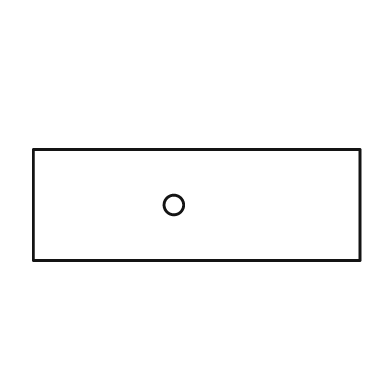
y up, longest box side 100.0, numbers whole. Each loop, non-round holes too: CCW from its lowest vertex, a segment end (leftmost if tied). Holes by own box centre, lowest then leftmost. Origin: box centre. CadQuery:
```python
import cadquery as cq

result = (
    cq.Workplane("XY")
    .moveTo(-50.0, -17.0)
    .lineTo(50.0, -17.0)
    .lineTo(50.0, 17.0)
    .lineTo(-50.0, 17.0)
    .close()
    .moveTo(-7.0, 0.0)
    .circle(3.0)
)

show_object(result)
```